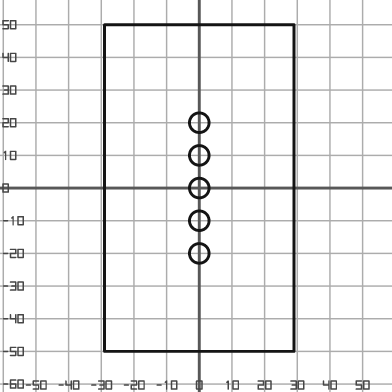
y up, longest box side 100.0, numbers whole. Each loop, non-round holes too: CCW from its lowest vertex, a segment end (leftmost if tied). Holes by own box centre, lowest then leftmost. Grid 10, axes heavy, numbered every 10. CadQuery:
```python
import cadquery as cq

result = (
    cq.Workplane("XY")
    .moveTo(-29.0, -50.0)
    .lineTo(29.0, -50.0)
    .lineTo(29.0, 50.0)
    .lineTo(-29.0, 50.0)
    .close()
    .moveTo(0.0, -20.0)
    .circle(3.0)
    .moveTo(0.0, -10.0)
    .circle(3.0)
    .moveTo(0.0, 0.0)
    .circle(3.0)
    .moveTo(0.0, 10.0)
    .circle(3.0)
    .moveTo(0.0, 20.0)
    .circle(3.0)
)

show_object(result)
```